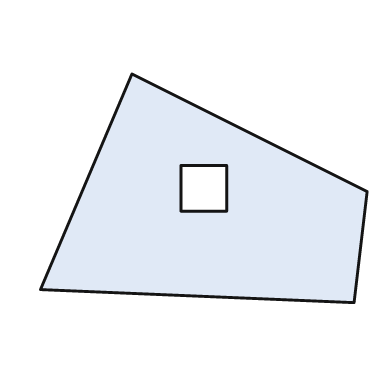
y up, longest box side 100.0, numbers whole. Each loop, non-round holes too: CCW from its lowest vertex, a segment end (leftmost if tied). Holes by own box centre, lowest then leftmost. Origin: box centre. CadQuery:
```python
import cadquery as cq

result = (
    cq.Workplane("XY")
    .moveTo(46.0, -35.0)
    .lineTo(50.0, -1.0)
    .lineTo(-22.0, 35.0)
    .lineTo(-50.0, -31.0)
    .close()
    .moveTo(-7.0, -7.0)
    .lineTo(7.0, -7.0)
    .lineTo(7.0, 7.0)
    .lineTo(-7.0, 7.0)
    .close()
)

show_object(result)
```